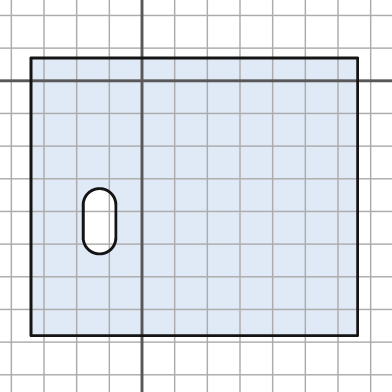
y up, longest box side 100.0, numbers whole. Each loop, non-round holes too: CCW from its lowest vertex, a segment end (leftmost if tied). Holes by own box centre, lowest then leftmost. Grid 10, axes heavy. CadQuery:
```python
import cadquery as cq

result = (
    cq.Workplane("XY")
    .moveTo(-34.0, -78.0)
    .lineTo(66.0, -78.0)
    .lineTo(66.0, 7.0)
    .lineTo(-34.0, 7.0)
    .close()
    .moveTo(-18.0, -48.0)
    .threePointArc((-13.0, -53.0), (-8.0, -48.0))
    .lineTo(-8.0, -38.0)
    .threePointArc((-13.0, -33.0), (-18.0, -38.0))
    .close()
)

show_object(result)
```